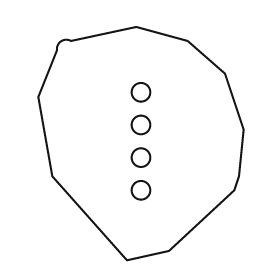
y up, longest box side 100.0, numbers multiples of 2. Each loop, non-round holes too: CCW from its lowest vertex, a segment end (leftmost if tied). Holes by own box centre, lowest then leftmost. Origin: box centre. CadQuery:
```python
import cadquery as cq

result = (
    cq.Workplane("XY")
    .moveTo(-6.0, -50.0)
    .lineTo(12.0, -46.0)
    .lineTo(40.0, -20.0)
    .lineTo(42.0, -14.0)
    .lineTo(44.0, 6.0)
    .lineTo(36.0, 30.0)
    .lineTo(20.0, 44.0)
    .lineTo(-2.0, 50.0)
    .lineTo(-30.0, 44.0)
    .threePointArc((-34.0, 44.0), (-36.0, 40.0))
    .lineTo(-44.0, 20.0)
    .lineTo(-38.0, -14.0)
    .close()
    .moveTo(0.0, -20.0)
    .circle(4.0)
    .moveTo(0.0, -6.0)
    .circle(4.0)
    .moveTo(0.0, 8.0)
    .circle(4.0)
    .moveTo(0.0, 22.0)
    .circle(4.0)
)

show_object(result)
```